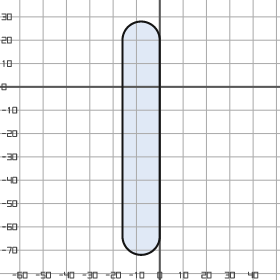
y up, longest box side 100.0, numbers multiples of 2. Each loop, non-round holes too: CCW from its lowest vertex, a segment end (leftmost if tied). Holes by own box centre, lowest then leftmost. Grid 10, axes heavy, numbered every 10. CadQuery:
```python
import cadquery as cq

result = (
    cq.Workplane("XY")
    .moveTo(-16.0, -64.0)
    .threePointArc((-8.0, -72.0), (0.0, -64.0))
    .lineTo(0.0, 20.0)
    .threePointArc((-8.0, 28.0), (-16.0, 20.0))
    .close()
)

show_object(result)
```